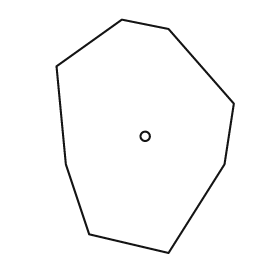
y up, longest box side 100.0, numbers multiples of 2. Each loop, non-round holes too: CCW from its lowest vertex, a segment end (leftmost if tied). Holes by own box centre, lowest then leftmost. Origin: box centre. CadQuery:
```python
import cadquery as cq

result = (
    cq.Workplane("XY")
    .moveTo(10.0, -50.0)
    .lineTo(34.0, -12.0)
    .lineTo(38.0, 14.0)
    .lineTo(10.0, 46.0)
    .lineTo(-10.0, 50.0)
    .lineTo(-38.0, 30.0)
    .lineTo(-34.0, -12.0)
    .lineTo(-24.0, -42.0)
    .close()
    .moveTo(0.0, 0.0)
    .circle(2.0)
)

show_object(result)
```